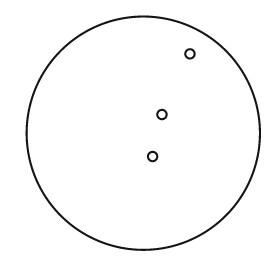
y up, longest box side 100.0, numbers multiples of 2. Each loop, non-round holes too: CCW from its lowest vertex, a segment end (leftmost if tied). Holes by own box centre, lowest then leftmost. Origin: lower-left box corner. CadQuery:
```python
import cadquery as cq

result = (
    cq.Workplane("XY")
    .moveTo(50.0, 50.0)
    .circle(50.0)
    .moveTo(54.0, 40.0)
    .circle(2.0)
    .moveTo(58.0, 58.0)
    .circle(2.0)
    .moveTo(70.0, 84.0)
    .circle(2.0)
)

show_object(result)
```